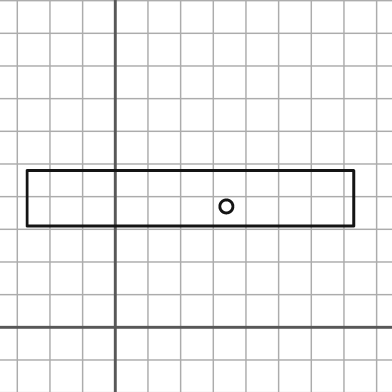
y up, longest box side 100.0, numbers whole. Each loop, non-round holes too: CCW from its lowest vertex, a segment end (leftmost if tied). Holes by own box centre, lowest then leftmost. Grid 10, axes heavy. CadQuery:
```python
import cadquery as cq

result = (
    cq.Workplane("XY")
    .moveTo(-27.0, 31.0)
    .lineTo(73.0, 31.0)
    .lineTo(73.0, 48.0)
    .lineTo(-27.0, 48.0)
    .close()
    .moveTo(34.0, 37.0)
    .circle(2.0)
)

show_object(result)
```